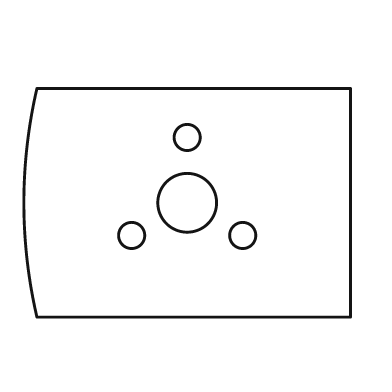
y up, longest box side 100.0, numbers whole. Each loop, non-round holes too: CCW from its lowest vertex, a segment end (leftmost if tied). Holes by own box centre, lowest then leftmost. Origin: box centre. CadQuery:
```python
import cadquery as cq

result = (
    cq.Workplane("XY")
    .moveTo(-46.0, -35.0)
    .lineTo(50.0, -35.0)
    .lineTo(50.0, 35.0)
    .lineTo(-46.0, 35.0)
    .threePointArc((-50.0, 0.0), (-46.0, -35.0))
    .close()
    .moveTo(-17.0, -10.0)
    .circle(4.0)
    .moveTo(17.0, -10.0)
    .circle(4.0)
    .moveTo(0.0, 0.0)
    .circle(9.0)
    .moveTo(0.0, 20.0)
    .circle(4.0)
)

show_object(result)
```